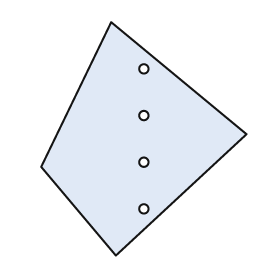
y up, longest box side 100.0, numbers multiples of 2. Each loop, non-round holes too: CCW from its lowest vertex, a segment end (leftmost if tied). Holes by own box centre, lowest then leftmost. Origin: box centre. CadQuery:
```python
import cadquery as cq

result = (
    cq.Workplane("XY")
    .moveTo(-12.0, -50.0)
    .lineTo(44.0, 2.0)
    .lineTo(-14.0, 50.0)
    .lineTo(-44.0, -12.0)
    .close()
    .moveTo(0.0, -30.0)
    .circle(2.0)
    .moveTo(0.0, -10.0)
    .circle(2.0)
    .moveTo(0.0, 10.0)
    .circle(2.0)
    .moveTo(0.0, 30.0)
    .circle(2.0)
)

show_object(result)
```